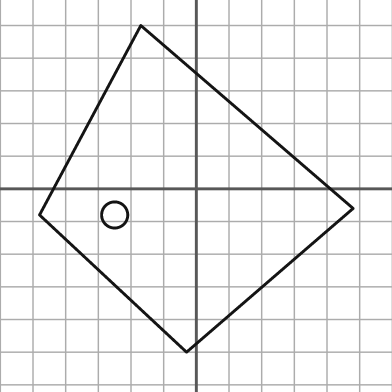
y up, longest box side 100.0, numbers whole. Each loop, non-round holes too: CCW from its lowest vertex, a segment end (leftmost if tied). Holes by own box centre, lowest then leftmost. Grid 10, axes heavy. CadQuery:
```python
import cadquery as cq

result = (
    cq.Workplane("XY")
    .moveTo(-3.0, -50.0)
    .lineTo(48.0, -6.0)
    .lineTo(-17.0, 50.0)
    .lineTo(-48.0, -8.0)
    .close()
    .moveTo(-25.0, -8.0)
    .circle(4.0)
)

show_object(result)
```